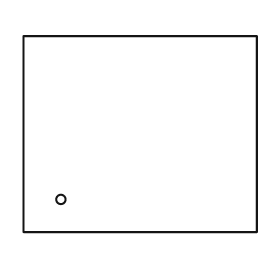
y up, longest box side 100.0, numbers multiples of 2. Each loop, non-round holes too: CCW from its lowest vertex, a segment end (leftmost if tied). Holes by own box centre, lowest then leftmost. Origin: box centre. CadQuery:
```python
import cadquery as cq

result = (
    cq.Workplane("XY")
    .moveTo(-50.0, -42.0)
    .lineTo(50.0, -42.0)
    .lineTo(50.0, 42.0)
    .lineTo(-50.0, 42.0)
    .close()
    .moveTo(-34.0, -28.0)
    .circle(2.0)
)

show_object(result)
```